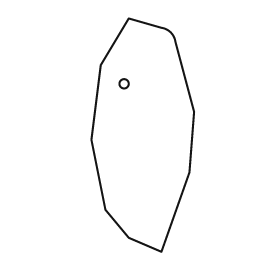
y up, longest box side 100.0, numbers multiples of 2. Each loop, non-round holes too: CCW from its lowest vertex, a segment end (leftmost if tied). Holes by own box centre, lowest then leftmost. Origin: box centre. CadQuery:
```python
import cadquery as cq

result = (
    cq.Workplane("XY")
    .moveTo(8.0, -50.0)
    .lineTo(20.0, -16.0)
    .lineTo(22.0, 10.0)
    .lineTo(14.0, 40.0)
    .threePointArc((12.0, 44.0), (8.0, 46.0))
    .lineTo(-6.0, 50.0)
    .lineTo(-18.0, 30.0)
    .lineTo(-22.0, -2.0)
    .lineTo(-16.0, -32.0)
    .lineTo(-6.0, -44.0)
    .close()
    .moveTo(-8.0, 22.0)
    .circle(2.0)
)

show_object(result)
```